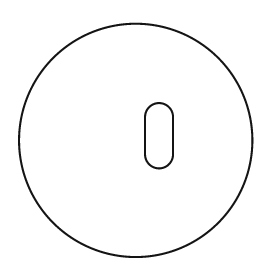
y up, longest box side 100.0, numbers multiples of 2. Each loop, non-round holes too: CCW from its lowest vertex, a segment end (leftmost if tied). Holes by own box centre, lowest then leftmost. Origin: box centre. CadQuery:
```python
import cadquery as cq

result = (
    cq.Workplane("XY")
    .moveTo(0.0, 0.0)
    .circle(50.0)
    .moveTo(4.0, -6.0)
    .threePointArc((10.0, -12.0), (16.0, -6.0))
    .lineTo(16.0, 10.0)
    .threePointArc((10.0, 16.0), (4.0, 10.0))
    .close()
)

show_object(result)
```